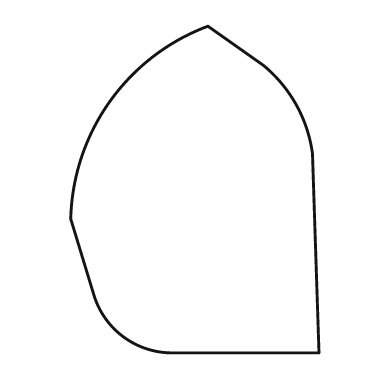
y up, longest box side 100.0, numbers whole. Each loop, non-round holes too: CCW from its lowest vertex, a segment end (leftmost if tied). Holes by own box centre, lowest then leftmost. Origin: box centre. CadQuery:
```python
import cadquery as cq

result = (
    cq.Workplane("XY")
    .moveTo(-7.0, -50.0)
    .lineTo(38.0, -50.0)
    .lineTo(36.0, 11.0)
    .threePointArc((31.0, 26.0), (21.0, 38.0))
    .lineTo(4.0, 50.0)
    .threePointArc((-26.0, 27.0), (-38.0, -9.0))
    .lineTo(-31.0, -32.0)
    .threePointArc((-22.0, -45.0), (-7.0, -50.0))
    .close()
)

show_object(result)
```